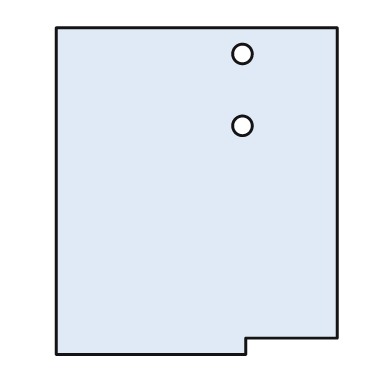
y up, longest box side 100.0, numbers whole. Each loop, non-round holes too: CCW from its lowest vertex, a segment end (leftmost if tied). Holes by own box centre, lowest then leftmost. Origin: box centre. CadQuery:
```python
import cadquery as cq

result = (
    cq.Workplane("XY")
    .moveTo(-43.0, -50.0)
    .lineTo(15.0, -50.0)
    .lineTo(15.0, -45.0)
    .lineTo(43.0, -45.0)
    .lineTo(43.0, 50.0)
    .lineTo(-43.0, 50.0)
    .close()
    .moveTo(14.0, 20.0)
    .circle(3.0)
    .moveTo(14.0, 42.0)
    .circle(3.0)
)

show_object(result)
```